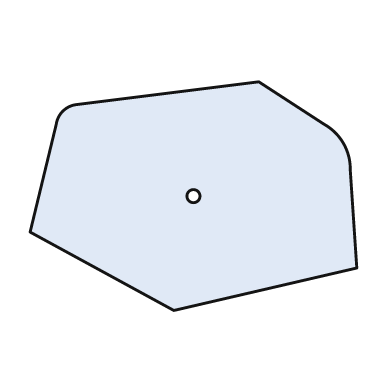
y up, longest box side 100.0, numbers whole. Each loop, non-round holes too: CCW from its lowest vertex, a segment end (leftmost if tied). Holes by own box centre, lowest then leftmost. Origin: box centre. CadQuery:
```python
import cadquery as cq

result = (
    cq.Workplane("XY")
    .moveTo(-6.0, -35.0)
    .lineTo(50.0, -22.0)
    .lineTo(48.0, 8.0)
    .threePointArc((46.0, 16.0), (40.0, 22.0))
    .lineTo(20.0, 35.0)
    .lineTo(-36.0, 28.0)
    .threePointArc((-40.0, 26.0), (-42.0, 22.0))
    .lineTo(-50.0, -11.0)
    .close()
    .moveTo(0.0, 0.0)
    .circle(2.0)
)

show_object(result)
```